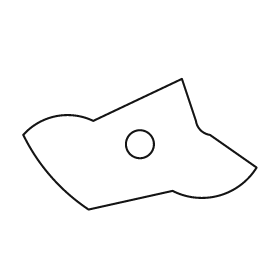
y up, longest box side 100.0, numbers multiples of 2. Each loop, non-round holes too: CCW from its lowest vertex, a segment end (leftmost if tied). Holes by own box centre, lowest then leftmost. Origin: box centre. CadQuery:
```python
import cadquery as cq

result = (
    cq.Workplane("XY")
    .moveTo(-22.0, -28.0)
    .lineTo(14.0, -20.0)
    .threePointArc((34.0, -22.0), (50.0, -10.0))
    .lineTo(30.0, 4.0)
    .threePointArc((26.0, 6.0), (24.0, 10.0))
    .lineTo(18.0, 28.0)
    .lineTo(-20.0, 10.0)
    .threePointArc((-36.0, 12.0), (-50.0, 4.0))
    .threePointArc((-38.0, -14.0), (-22.0, -28.0))
    .close()
    .moveTo(0.0, 0.0)
    .circle(6.0)
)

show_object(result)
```